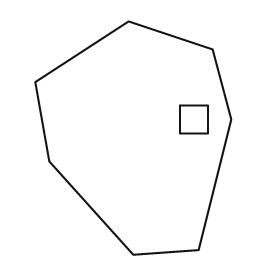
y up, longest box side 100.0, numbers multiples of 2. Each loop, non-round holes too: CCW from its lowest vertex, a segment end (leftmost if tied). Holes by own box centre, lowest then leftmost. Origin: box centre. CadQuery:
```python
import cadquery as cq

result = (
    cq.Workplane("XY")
    .moveTo(0.0, -50.0)
    .lineTo(28.0, -48.0)
    .lineTo(42.0, 8.0)
    .lineTo(34.0, 38.0)
    .lineTo(-2.0, 50.0)
    .lineTo(-42.0, 24.0)
    .lineTo(-36.0, -10.0)
    .close()
    .moveTo(20.0, 2.0)
    .lineTo(32.0, 2.0)
    .lineTo(32.0, 14.0)
    .lineTo(20.0, 14.0)
    .close()
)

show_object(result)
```